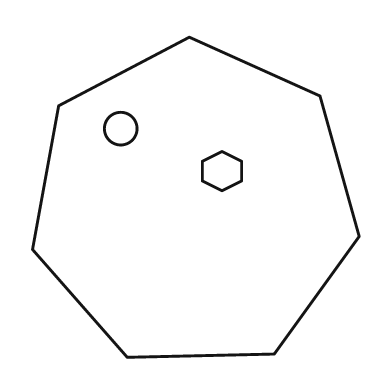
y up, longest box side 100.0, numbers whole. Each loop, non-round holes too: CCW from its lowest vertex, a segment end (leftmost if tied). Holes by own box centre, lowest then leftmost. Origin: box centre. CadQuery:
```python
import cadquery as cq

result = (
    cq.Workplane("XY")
    .moveTo(-21.0, -49.0)
    .lineTo(24.0, -48.0)
    .lineTo(50.0, -12.0)
    .lineTo(38.0, 31.0)
    .lineTo(-2.0, 49.0)
    .lineTo(-42.0, 28.0)
    .lineTo(-50.0, -16.0)
    .close()
    .moveTo(8.0, 2.0)
    .lineTo(14.0, 5.0)
    .lineTo(14.0, 11.0)
    .lineTo(8.0, 14.0)
    .lineTo(2.0, 11.0)
    .lineTo(2.0, 5.0)
    .close()
    .moveTo(-23.0, 21.0)
    .circle(5.0)
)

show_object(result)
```